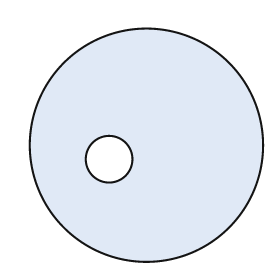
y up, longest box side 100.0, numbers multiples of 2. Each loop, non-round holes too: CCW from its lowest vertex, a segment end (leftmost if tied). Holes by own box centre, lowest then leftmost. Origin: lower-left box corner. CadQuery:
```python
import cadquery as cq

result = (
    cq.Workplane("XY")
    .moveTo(50.0, 50.0)
    .circle(50.0)
    .moveTo(34.0, 44.0)
    .circle(10.0)
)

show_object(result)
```